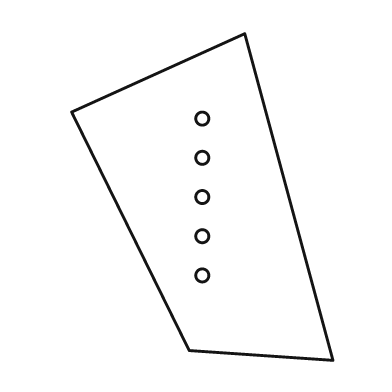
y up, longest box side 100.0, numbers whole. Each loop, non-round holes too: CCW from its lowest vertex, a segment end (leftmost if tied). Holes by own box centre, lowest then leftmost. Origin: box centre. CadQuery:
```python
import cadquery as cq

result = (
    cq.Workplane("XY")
    .moveTo(40.0, -50.0)
    .lineTo(13.0, 50.0)
    .lineTo(-40.0, 26.0)
    .lineTo(-4.0, -47.0)
    .close()
    .moveTo(0.0, -24.0)
    .circle(2.0)
    .moveTo(0.0, -12.0)
    .circle(2.0)
    .moveTo(0.0, 0.0)
    .circle(2.0)
    .moveTo(0.0, 12.0)
    .circle(2.0)
    .moveTo(0.0, 24.0)
    .circle(2.0)
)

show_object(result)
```